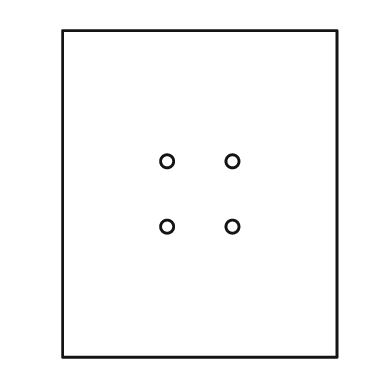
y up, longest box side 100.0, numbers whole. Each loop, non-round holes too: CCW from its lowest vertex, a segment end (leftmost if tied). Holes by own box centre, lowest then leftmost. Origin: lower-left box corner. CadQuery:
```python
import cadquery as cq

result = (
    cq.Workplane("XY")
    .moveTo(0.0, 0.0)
    .lineTo(84.0, 0.0)
    .lineTo(84.0, 100.0)
    .lineTo(0.0, 100.0)
    .close()
    .moveTo(32.0, 40.0)
    .circle(2.0)
    .moveTo(52.0, 40.0)
    .circle(2.0)
    .moveTo(32.0, 60.0)
    .circle(2.0)
    .moveTo(52.0, 60.0)
    .circle(2.0)
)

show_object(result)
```